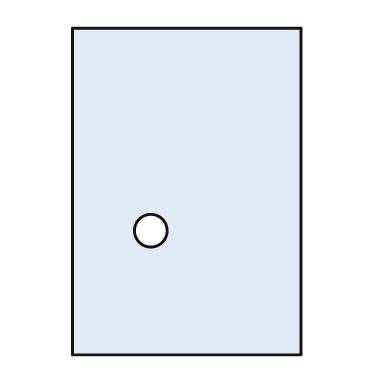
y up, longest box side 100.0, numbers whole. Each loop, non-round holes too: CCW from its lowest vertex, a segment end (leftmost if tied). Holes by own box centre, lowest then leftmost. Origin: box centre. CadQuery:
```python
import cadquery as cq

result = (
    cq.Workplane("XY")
    .moveTo(-35.0, -50.0)
    .lineTo(35.0, -50.0)
    .lineTo(35.0, 50.0)
    .lineTo(-35.0, 50.0)
    .close()
    .moveTo(-11.0, -12.0)
    .circle(5.0)
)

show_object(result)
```